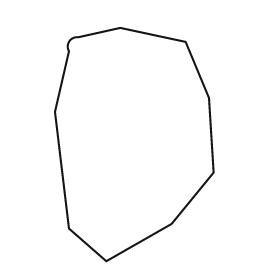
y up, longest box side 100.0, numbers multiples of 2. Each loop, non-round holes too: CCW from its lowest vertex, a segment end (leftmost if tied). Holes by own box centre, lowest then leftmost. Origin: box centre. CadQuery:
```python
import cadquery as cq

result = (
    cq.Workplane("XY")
    .moveTo(-12.0, -50.0)
    .lineTo(16.0, -34.0)
    .lineTo(34.0, -12.0)
    .lineTo(32.0, 20.0)
    .lineTo(22.0, 44.0)
    .lineTo(-6.0, 50.0)
    .lineTo(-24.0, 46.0)
    .threePointArc((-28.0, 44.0), (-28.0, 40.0))
    .lineTo(-34.0, 14.0)
    .lineTo(-28.0, -36.0)
    .close()
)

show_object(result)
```